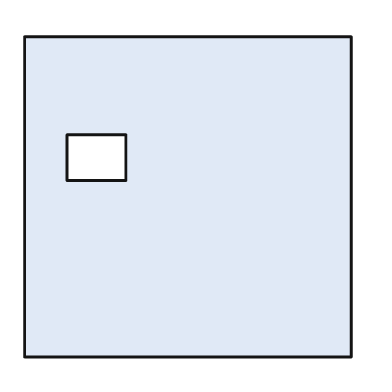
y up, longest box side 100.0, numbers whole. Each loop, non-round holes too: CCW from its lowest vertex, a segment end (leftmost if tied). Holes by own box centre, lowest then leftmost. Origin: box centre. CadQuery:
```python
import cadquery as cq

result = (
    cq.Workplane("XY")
    .moveTo(-50.0, -49.0)
    .lineTo(50.0, -49.0)
    .lineTo(50.0, 49.0)
    .lineTo(-50.0, 49.0)
    .close()
    .moveTo(-37.0, 5.0)
    .lineTo(-19.0, 5.0)
    .lineTo(-19.0, 19.0)
    .lineTo(-37.0, 19.0)
    .close()
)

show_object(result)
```